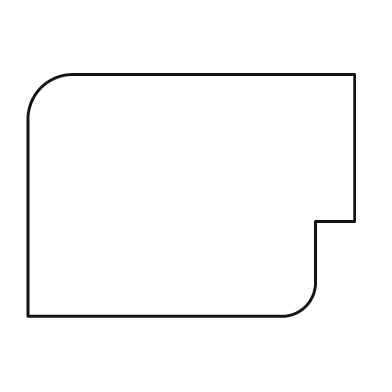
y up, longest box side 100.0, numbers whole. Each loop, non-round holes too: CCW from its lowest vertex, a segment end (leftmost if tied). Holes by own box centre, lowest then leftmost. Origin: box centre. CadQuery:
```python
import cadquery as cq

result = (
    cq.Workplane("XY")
    .moveTo(-50.0, -37.0)
    .lineTo(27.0, -37.0)
    .threePointArc((35.0, -34.0), (38.0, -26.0))
    .lineTo(38.0, -8.0)
    .lineTo(50.0, -8.0)
    .lineTo(50.0, 37.0)
    .lineTo(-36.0, 37.0)
    .threePointArc((-46.0, 33.0), (-50.0, 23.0))
    .close()
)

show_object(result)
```